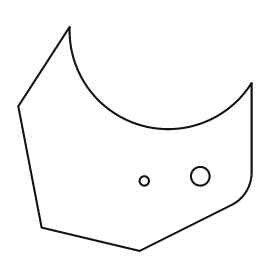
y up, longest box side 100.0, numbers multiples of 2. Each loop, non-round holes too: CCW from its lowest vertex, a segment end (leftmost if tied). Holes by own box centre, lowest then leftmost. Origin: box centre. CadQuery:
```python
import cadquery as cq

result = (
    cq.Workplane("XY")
    .moveTo(2.0, -48.0)
    .lineTo(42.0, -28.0)
    .threePointArc((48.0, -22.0), (50.0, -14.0))
    .lineTo(50.0, 24.0)
    .threePointArc((2.0, 6.0), (-28.0, 48.0))
    .lineTo(-50.0, 14.0)
    .lineTo(-40.0, -38.0)
    .close()
    .moveTo(4.0, -18.0)
    .circle(2.0)
    .moveTo(28.0, -16.0)
    .circle(4.0)
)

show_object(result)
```